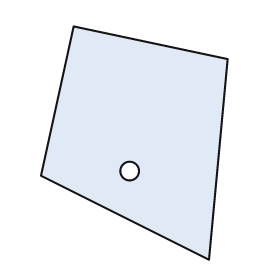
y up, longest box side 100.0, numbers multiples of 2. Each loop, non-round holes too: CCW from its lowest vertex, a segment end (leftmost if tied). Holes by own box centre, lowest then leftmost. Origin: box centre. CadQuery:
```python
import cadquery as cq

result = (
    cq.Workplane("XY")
    .moveTo(32.0, -50.0)
    .lineTo(40.0, 36.0)
    .lineTo(-26.0, 50.0)
    .lineTo(-40.0, -14.0)
    .close()
    .moveTo(-2.0, -12.0)
    .circle(4.0)
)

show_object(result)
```